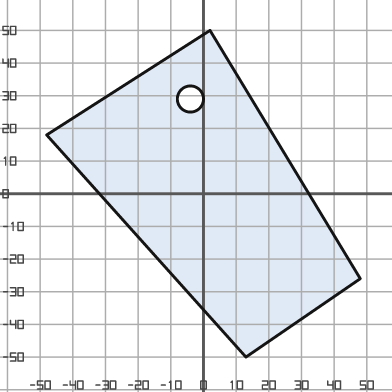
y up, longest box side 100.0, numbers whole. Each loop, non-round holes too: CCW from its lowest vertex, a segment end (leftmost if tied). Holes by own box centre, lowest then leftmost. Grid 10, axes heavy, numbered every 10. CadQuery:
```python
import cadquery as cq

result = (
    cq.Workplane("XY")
    .moveTo(13.0, -50.0)
    .lineTo(48.0, -26.0)
    .lineTo(2.0, 50.0)
    .lineTo(-48.0, 18.0)
    .close()
    .moveTo(-4.0, 29.0)
    .circle(4.0)
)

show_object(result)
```